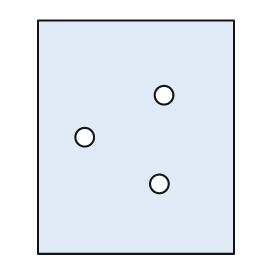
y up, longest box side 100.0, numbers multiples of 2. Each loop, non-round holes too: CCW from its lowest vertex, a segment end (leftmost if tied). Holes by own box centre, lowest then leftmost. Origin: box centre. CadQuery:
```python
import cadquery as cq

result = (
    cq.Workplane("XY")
    .moveTo(-42.0, -50.0)
    .lineTo(42.0, -50.0)
    .lineTo(42.0, 50.0)
    .lineTo(-42.0, 50.0)
    .close()
    .moveTo(10.0, -20.0)
    .circle(4.0)
    .moveTo(-22.0, 0.0)
    .circle(4.0)
    .moveTo(12.0, 18.0)
    .circle(4.0)
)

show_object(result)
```